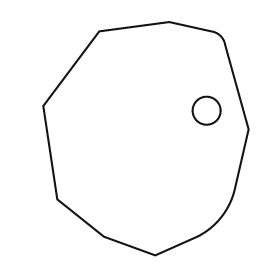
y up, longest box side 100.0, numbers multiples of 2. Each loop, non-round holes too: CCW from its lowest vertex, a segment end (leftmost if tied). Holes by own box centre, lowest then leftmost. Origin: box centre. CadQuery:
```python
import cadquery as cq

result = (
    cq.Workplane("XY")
    .moveTo(4.0, -50.0)
    .lineTo(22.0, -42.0)
    .threePointArc((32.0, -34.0), (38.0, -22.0))
    .lineTo(44.0, 4.0)
    .lineTo(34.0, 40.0)
    .threePointArc((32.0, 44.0), (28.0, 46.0))
    .lineTo(10.0, 50.0)
    .lineTo(-20.0, 46.0)
    .lineTo(-44.0, 14.0)
    .lineTo(-38.0, -26.0)
    .lineTo(-18.0, -42.0)
    .close()
    .moveTo(26.0, 12.0)
    .circle(6.0)
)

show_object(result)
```